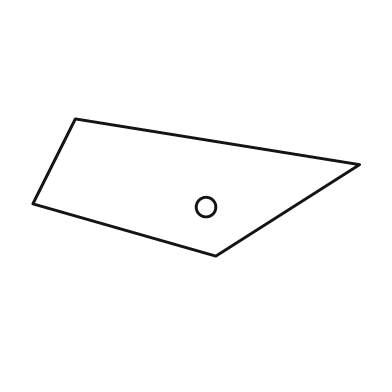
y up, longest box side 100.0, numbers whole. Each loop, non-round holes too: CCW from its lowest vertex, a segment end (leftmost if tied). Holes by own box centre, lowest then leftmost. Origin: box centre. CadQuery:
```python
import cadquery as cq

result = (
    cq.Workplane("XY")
    .moveTo(6.0, -21.0)
    .lineTo(50.0, 7.0)
    .lineTo(-37.0, 21.0)
    .lineTo(-50.0, -5.0)
    .close()
    .moveTo(3.0, -6.0)
    .circle(3.0)
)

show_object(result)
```